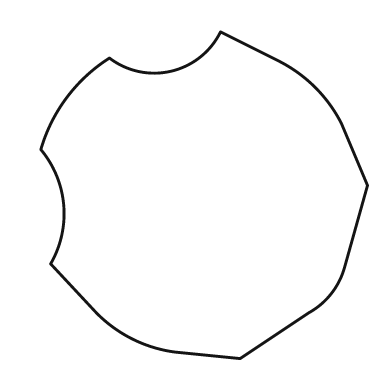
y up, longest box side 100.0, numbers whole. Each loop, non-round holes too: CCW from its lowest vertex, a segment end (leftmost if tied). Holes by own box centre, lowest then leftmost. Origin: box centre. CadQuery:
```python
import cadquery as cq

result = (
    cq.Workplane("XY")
    .moveTo(11.0, -50.0)
    .lineTo(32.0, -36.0)
    .threePointArc((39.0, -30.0), (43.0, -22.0))
    .lineTo(50.0, 3.0)
    .lineTo(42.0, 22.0)
    .threePointArc((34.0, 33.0), (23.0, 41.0))
    .lineTo(5.0, 50.0)
    .threePointArc((-10.0, 38.0), (-29.0, 42.0))
    .threePointArc((-42.0, 30.0), (-50.0, 14.0))
    .threePointArc((-43.0, -3.0), (-47.0, -21.0))
    .lineTo(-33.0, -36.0)
    .threePointArc((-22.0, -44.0), (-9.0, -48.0))
    .close()
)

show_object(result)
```